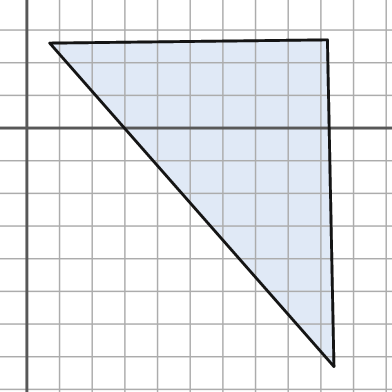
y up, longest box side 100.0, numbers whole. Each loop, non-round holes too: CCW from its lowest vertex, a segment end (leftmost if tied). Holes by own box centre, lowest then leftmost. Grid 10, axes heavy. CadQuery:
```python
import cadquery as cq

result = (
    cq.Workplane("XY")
    .moveTo(94.0, -73.0)
    .lineTo(92.0, 27.0)
    .lineTo(7.0, 26.0)
    .close()
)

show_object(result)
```